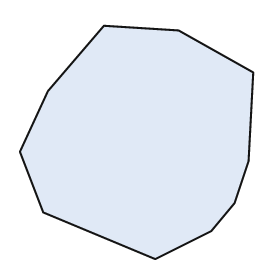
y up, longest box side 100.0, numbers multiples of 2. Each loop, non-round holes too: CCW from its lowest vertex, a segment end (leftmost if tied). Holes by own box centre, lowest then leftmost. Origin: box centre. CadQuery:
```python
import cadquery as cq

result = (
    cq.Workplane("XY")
    .moveTo(8.0, -50.0)
    .lineTo(32.0, -38.0)
    .lineTo(42.0, -26.0)
    .lineTo(48.0, -8.0)
    .lineTo(50.0, 30.0)
    .lineTo(18.0, 48.0)
    .lineTo(-14.0, 50.0)
    .lineTo(-38.0, 22.0)
    .lineTo(-50.0, -4.0)
    .lineTo(-40.0, -30.0)
    .close()
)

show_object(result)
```